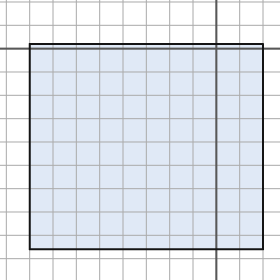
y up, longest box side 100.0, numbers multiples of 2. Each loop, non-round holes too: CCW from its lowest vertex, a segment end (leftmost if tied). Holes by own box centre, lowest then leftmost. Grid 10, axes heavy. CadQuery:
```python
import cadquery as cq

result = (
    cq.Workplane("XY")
    .moveTo(-80.0, -86.0)
    .lineTo(20.0, -86.0)
    .lineTo(20.0, 2.0)
    .lineTo(-80.0, 2.0)
    .close()
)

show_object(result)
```